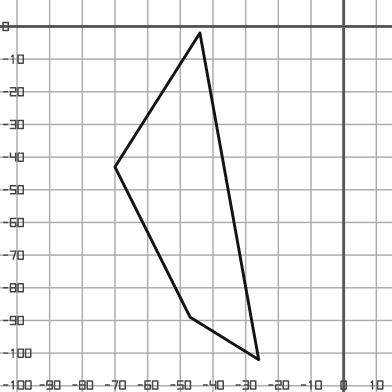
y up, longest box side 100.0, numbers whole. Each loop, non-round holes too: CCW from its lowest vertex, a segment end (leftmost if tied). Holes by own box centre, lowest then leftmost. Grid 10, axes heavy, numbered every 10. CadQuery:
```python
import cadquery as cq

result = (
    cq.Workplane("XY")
    .moveTo(-26.0, -102.0)
    .lineTo(-44.0, -2.0)
    .lineTo(-70.0, -43.0)
    .lineTo(-47.0, -89.0)
    .close()
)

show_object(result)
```